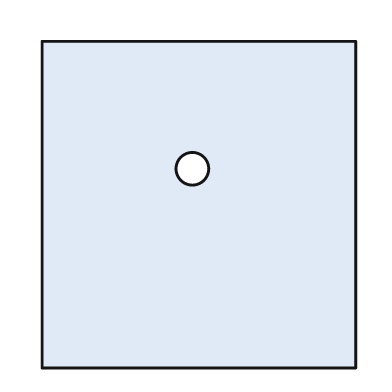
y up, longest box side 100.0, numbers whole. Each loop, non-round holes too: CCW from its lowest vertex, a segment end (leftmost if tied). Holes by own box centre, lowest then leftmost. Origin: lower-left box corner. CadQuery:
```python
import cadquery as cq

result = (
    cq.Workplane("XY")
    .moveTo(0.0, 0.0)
    .lineTo(96.0, 0.0)
    .lineTo(96.0, 100.0)
    .lineTo(0.0, 100.0)
    .close()
    .moveTo(46.0, 61.0)
    .circle(5.0)
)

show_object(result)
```